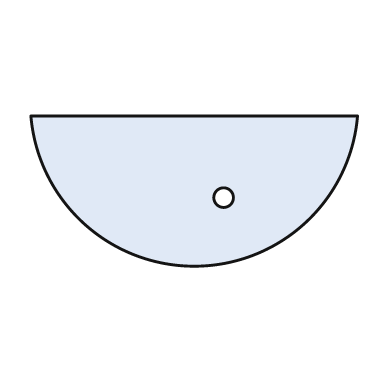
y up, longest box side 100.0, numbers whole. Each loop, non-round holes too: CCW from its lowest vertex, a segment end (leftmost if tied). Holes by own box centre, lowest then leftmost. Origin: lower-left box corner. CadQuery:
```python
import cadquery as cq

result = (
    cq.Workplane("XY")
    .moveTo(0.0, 46.0)
    .threePointArc((50.0, 0.0), (100.0, 46.0))
    .close()
    .moveTo(59.0, 21.0)
    .circle(3.0)
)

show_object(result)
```